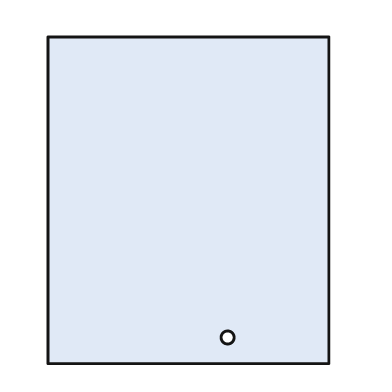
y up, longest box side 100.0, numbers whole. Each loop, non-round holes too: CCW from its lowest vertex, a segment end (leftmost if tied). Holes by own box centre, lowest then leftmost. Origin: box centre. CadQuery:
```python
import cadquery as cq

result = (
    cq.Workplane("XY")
    .moveTo(-43.0, -50.0)
    .lineTo(43.0, -50.0)
    .lineTo(43.0, 50.0)
    .lineTo(-43.0, 50.0)
    .close()
    .moveTo(12.0, -42.0)
    .circle(2.0)
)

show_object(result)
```